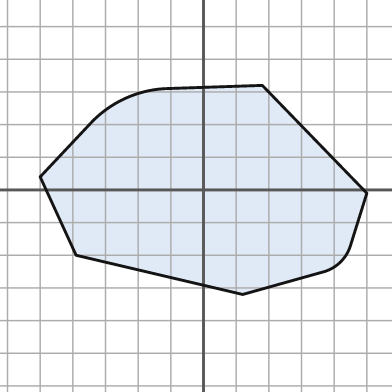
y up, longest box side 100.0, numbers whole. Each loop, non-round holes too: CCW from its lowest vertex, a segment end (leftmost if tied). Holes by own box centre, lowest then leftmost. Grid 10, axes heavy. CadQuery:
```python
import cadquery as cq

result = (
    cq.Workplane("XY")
    .moveTo(12.0, -32.0)
    .lineTo(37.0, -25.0)
    .threePointArc((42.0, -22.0), (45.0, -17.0))
    .lineTo(50.0, -1.0)
    .lineTo(18.0, 32.0)
    .lineTo(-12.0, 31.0)
    .threePointArc((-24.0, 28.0), (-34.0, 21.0))
    .lineTo(-50.0, 4.0)
    .lineTo(-39.0, -20.0)
    .close()
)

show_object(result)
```